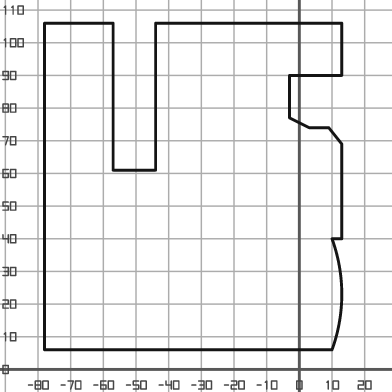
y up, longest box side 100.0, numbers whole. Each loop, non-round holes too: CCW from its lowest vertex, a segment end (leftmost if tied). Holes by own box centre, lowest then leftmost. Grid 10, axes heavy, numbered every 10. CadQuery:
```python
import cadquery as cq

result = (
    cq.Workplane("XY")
    .moveTo(-78.0, 6.0)
    .lineTo(10.0, 6.0)
    .threePointArc((13.0, 23.0), (10.0, 40.0))
    .lineTo(13.0, 40.0)
    .lineTo(13.0, 69.0)
    .lineTo(9.0, 74.0)
    .lineTo(3.0, 74.0)
    .lineTo(-3.0, 77.0)
    .lineTo(-3.0, 90.0)
    .lineTo(13.0, 90.0)
    .lineTo(13.0, 106.0)
    .lineTo(-44.0, 106.0)
    .lineTo(-44.0, 61.0)
    .lineTo(-57.0, 61.0)
    .lineTo(-57.0, 106.0)
    .lineTo(-78.0, 106.0)
    .close()
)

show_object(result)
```